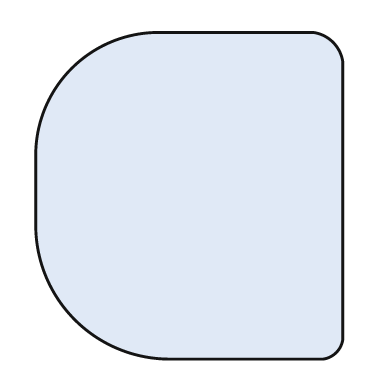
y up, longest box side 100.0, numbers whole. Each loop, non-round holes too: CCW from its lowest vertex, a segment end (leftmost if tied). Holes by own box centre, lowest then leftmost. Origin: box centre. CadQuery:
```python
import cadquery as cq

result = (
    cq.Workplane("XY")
    .moveTo(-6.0, -50.0)
    .lineTo(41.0, -50.0)
    .threePointArc((45.0, -48.0), (47.0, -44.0))
    .lineTo(47.0, 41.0)
    .threePointArc((44.0, 47.0), (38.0, 50.0))
    .lineTo(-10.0, 50.0)
    .threePointArc((-36.0, 39.0), (-47.0, 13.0))
    .lineTo(-47.0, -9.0)
    .threePointArc((-35.0, -38.0), (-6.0, -50.0))
    .close()
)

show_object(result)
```